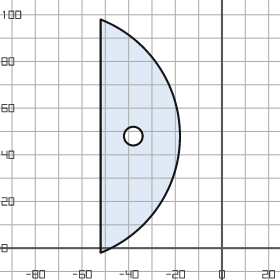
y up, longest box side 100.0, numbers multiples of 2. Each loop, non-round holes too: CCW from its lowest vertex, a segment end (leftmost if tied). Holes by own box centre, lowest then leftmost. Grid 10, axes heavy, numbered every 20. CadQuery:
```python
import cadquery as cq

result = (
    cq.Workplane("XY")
    .moveTo(-52.0, -2.0)
    .threePointArc((-18.0, 48.0), (-52.0, 98.0))
    .close()
    .moveTo(-38.0, 48.0)
    .circle(4.0)
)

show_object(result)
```